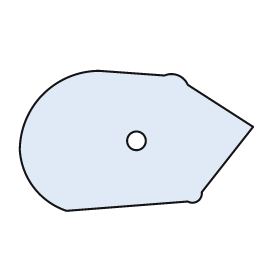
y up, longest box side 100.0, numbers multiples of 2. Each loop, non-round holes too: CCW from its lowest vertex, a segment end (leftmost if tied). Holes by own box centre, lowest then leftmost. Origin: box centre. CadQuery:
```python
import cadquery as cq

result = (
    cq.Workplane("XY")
    .moveTo(-30.0, -30.0)
    .lineTo(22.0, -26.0)
    .threePointArc((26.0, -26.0), (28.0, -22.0))
    .lineTo(50.0, 6.0)
    .lineTo(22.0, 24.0)
    .threePointArc((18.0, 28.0), (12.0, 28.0))
    .lineTo(-16.0, 30.0)
    .threePointArc((-40.0, 20.0), (-50.0, -4.0))
    .threePointArc((-44.0, -20.0), (-30.0, -30.0))
    .close()
    .moveTo(0.0, 0.0)
    .circle(4.0)
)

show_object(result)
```